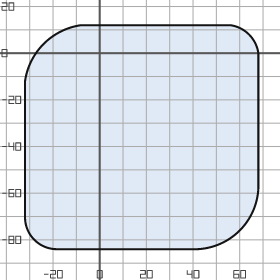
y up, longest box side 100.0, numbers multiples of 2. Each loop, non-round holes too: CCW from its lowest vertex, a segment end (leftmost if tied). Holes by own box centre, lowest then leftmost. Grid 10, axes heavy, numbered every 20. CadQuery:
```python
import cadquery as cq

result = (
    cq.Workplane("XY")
    .moveTo(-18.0, -84.0)
    .lineTo(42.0, -84.0)
    .threePointArc((60.0, -76.0), (68.0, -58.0))
    .lineTo(68.0, 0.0)
    .threePointArc((64.0, 8.0), (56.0, 12.0))
    .lineTo(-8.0, 12.0)
    .threePointArc((-24.0, 4.0), (-32.0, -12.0))
    .lineTo(-32.0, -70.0)
    .threePointArc((-28.0, -80.0), (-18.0, -84.0))
    .close()
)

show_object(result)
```